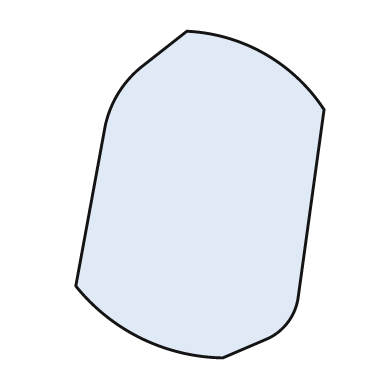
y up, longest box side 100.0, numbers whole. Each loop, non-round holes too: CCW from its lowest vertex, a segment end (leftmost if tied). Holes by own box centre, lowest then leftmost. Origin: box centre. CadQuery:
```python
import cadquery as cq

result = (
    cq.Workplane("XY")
    .moveTo(7.0, -50.0)
    .lineTo(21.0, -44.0)
    .threePointArc((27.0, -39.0), (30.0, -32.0))
    .lineTo(38.0, 26.0)
    .threePointArc((20.0, 43.0), (-4.0, 50.0))
    .lineTo(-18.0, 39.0)
    .threePointArc((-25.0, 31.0), (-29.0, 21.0))
    .lineTo(-38.0, -28.0)
    .threePointArc((-18.0, -44.0), (7.0, -50.0))
    .close()
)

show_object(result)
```